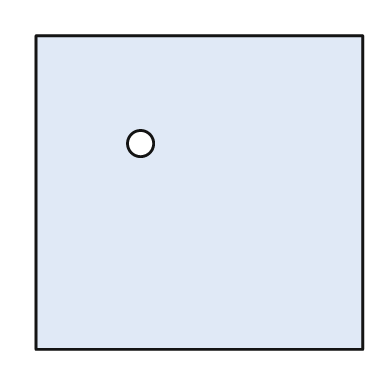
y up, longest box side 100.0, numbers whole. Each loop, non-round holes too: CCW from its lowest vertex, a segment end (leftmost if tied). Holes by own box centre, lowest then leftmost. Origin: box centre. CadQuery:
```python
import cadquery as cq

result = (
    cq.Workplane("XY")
    .moveTo(-50.0, -48.0)
    .lineTo(50.0, -48.0)
    .lineTo(50.0, 48.0)
    .lineTo(-50.0, 48.0)
    .close()
    .moveTo(-18.0, 15.0)
    .circle(4.0)
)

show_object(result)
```